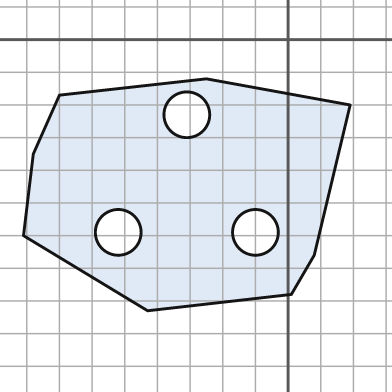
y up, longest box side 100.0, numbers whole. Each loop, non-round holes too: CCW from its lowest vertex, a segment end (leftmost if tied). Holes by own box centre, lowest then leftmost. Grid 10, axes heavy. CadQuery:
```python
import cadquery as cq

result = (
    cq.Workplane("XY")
    .moveTo(-43.0, -83.0)
    .lineTo(1.0, -78.0)
    .lineTo(8.0, -66.0)
    .lineTo(19.0, -20.0)
    .lineTo(-25.0, -12.0)
    .lineTo(-70.0, -17.0)
    .lineTo(-78.0, -35.0)
    .lineTo(-81.0, -60.0)
    .close()
    .moveTo(-52.0, -59.0)
    .circle(7.0)
    .moveTo(-10.0, -59.0)
    .circle(7.0)
    .moveTo(-31.0, -23.0)
    .circle(7.0)
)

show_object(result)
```